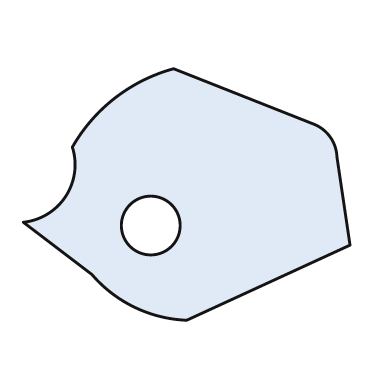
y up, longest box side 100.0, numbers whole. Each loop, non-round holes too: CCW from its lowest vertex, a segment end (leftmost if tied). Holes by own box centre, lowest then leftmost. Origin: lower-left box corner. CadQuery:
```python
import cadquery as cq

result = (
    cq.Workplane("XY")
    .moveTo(50.0, 0.0)
    .lineTo(100.0, 23.0)
    .lineTo(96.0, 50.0)
    .threePointArc((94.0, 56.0), (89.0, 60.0))
    .lineTo(46.0, 77.0)
    .threePointArc((28.0, 68.0), (15.0, 53.0))
    .threePointArc((13.0, 38.0), (0.0, 30.0))
    .lineTo(21.0, 14.0)
    .threePointArc((34.0, 4.0), (50.0, 0.0))
    .close()
    .moveTo(39.0, 29.0)
    .circle(9.0)
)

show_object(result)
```